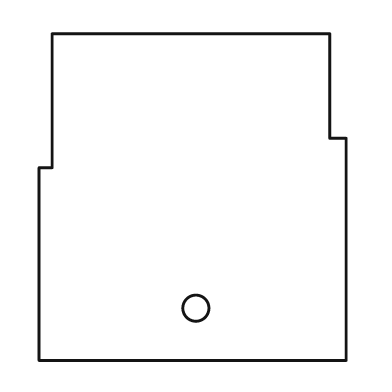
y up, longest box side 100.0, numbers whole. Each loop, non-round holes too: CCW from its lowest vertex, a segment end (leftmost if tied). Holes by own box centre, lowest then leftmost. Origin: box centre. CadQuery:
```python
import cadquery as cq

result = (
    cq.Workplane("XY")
    .moveTo(-47.0, -50.0)
    .lineTo(47.0, -50.0)
    .lineTo(47.0, 18.0)
    .lineTo(42.0, 18.0)
    .lineTo(42.0, 50.0)
    .lineTo(-43.0, 50.0)
    .lineTo(-43.0, 9.0)
    .lineTo(-47.0, 9.0)
    .close()
    .moveTo(1.0, -34.0)
    .circle(4.0)
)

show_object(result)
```